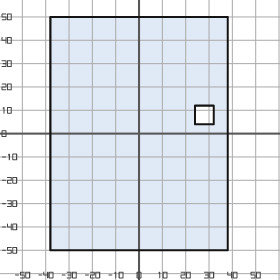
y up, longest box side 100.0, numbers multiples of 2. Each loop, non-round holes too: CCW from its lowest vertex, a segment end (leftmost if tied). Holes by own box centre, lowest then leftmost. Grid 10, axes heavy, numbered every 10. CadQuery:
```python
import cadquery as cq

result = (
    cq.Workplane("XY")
    .moveTo(-38.0, -50.0)
    .lineTo(38.0, -50.0)
    .lineTo(38.0, 50.0)
    .lineTo(-38.0, 50.0)
    .close()
    .moveTo(24.0, 4.0)
    .lineTo(32.0, 4.0)
    .lineTo(32.0, 12.0)
    .lineTo(24.0, 12.0)
    .close()
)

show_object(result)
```